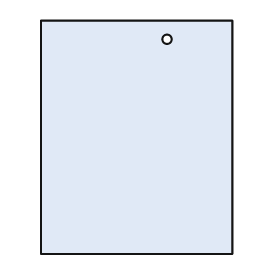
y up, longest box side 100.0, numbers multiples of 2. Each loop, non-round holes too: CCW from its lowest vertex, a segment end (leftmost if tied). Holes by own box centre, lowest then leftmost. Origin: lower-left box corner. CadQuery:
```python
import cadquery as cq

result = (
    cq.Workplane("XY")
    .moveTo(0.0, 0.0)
    .lineTo(82.0, 0.0)
    .lineTo(82.0, 100.0)
    .lineTo(0.0, 100.0)
    .close()
    .moveTo(54.0, 92.0)
    .circle(2.0)
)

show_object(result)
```